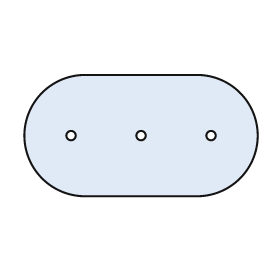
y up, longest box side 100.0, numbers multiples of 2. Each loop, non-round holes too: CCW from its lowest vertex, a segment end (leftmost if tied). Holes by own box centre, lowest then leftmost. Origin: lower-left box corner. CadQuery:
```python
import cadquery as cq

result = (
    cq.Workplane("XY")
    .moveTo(26.0, 0.0)
    .lineTo(74.0, 0.0)
    .threePointArc((100.0, 26.0), (74.0, 52.0))
    .lineTo(26.0, 52.0)
    .threePointArc((0.0, 26.0), (26.0, 0.0))
    .close()
    .moveTo(20.0, 26.0)
    .circle(2.0)
    .moveTo(50.0, 26.0)
    .circle(2.0)
    .moveTo(80.0, 26.0)
    .circle(2.0)
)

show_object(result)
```